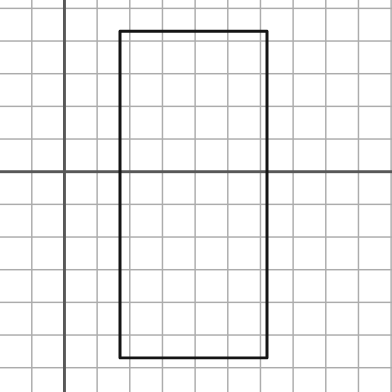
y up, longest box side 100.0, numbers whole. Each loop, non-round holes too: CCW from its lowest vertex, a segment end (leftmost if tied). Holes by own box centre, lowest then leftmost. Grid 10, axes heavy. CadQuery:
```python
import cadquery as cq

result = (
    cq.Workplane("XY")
    .moveTo(17.0, -57.0)
    .lineTo(62.0, -57.0)
    .lineTo(62.0, 43.0)
    .lineTo(17.0, 43.0)
    .close()
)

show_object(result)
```